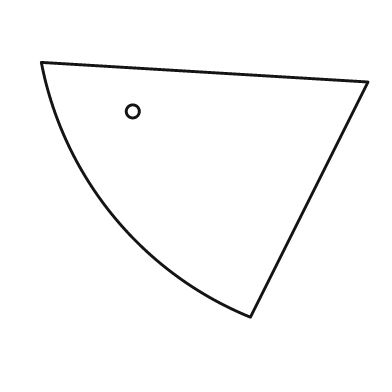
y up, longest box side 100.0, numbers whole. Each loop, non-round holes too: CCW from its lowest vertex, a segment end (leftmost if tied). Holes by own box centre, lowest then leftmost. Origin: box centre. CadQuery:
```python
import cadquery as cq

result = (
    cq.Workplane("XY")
    .moveTo(14.0, -39.0)
    .lineTo(50.0, 33.0)
    .lineTo(-50.0, 39.0)
    .threePointArc((-28.0, -8.0), (14.0, -39.0))
    .close()
    .moveTo(-22.0, 24.0)
    .circle(2.0)
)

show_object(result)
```